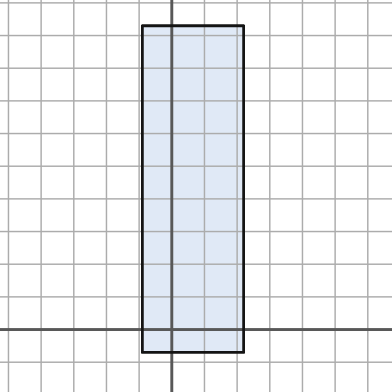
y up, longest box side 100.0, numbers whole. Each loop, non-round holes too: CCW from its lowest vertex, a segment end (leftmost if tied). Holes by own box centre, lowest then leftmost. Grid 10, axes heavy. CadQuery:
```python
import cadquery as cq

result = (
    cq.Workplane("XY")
    .moveTo(-9.0, -7.0)
    .lineTo(22.0, -7.0)
    .lineTo(22.0, 93.0)
    .lineTo(-9.0, 93.0)
    .close()
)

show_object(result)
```